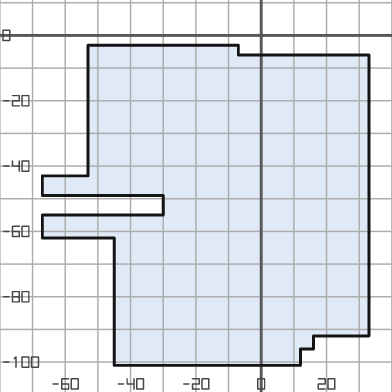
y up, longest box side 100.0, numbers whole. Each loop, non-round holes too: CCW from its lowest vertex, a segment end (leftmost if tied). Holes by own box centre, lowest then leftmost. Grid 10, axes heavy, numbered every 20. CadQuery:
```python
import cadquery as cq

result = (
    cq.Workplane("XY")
    .moveTo(-45.0, -101.0)
    .lineTo(12.0, -101.0)
    .lineTo(12.0, -96.0)
    .lineTo(16.0, -96.0)
    .lineTo(16.0, -92.0)
    .lineTo(33.0, -92.0)
    .lineTo(33.0, -6.0)
    .lineTo(-7.0, -6.0)
    .lineTo(-7.0, -3.0)
    .lineTo(-53.0, -3.0)
    .lineTo(-53.0, -43.0)
    .lineTo(-67.0, -43.0)
    .lineTo(-67.0, -49.0)
    .lineTo(-30.0, -49.0)
    .lineTo(-30.0, -55.0)
    .lineTo(-67.0, -55.0)
    .lineTo(-67.0, -62.0)
    .lineTo(-45.0, -62.0)
    .close()
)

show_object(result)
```